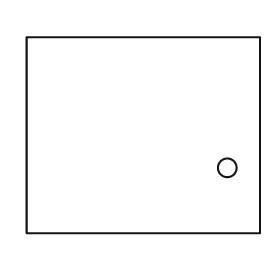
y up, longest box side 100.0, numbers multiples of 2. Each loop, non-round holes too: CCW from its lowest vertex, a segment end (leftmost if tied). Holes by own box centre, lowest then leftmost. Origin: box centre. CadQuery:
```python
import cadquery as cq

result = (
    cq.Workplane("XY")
    .moveTo(-50.0, -42.0)
    .lineTo(50.0, -42.0)
    .lineTo(50.0, 42.0)
    .lineTo(-50.0, 42.0)
    .close()
    .moveTo(36.0, -14.0)
    .circle(4.0)
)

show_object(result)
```